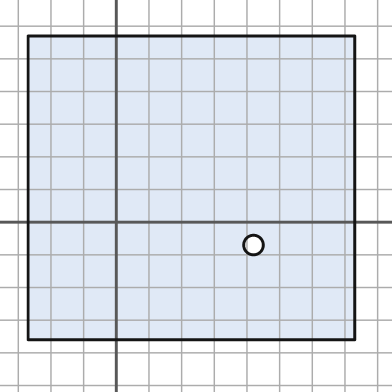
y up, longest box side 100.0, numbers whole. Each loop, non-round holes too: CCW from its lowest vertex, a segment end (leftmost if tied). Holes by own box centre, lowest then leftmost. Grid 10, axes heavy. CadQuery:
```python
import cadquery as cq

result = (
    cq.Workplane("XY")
    .moveTo(-27.0, -36.0)
    .lineTo(73.0, -36.0)
    .lineTo(73.0, 57.0)
    .lineTo(-27.0, 57.0)
    .close()
    .moveTo(42.0, -7.0)
    .circle(3.0)
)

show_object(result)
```